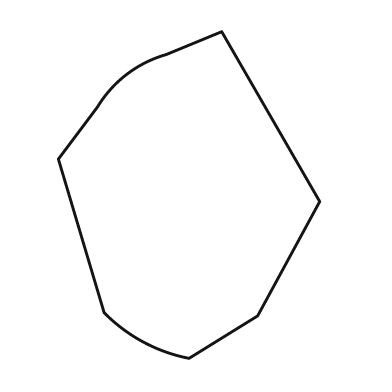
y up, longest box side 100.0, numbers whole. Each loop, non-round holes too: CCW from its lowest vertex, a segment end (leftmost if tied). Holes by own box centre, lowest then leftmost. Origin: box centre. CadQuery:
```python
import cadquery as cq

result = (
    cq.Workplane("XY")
    .moveTo(0.0, -50.0)
    .lineTo(21.0, -37.0)
    .lineTo(40.0, -2.0)
    .lineTo(10.0, 50.0)
    .lineTo(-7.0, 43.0)
    .threePointArc((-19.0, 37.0), (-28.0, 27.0))
    .lineTo(-40.0, 11.0)
    .lineTo(-26.0, -36.0)
    .threePointArc((-14.0, -45.0), (0.0, -50.0))
    .close()
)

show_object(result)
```